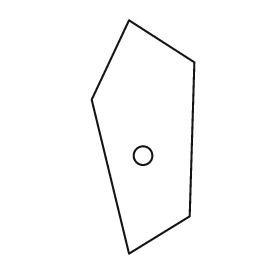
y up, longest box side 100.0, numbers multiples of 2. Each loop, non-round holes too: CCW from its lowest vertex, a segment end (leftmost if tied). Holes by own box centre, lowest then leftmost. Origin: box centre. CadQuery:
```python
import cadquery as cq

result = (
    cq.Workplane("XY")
    .moveTo(-6.0, -50.0)
    .lineTo(20.0, -34.0)
    .lineTo(22.0, 32.0)
    .lineTo(-6.0, 50.0)
    .lineTo(-22.0, 16.0)
    .close()
    .moveTo(0.0, -8.0)
    .circle(4.0)
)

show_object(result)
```